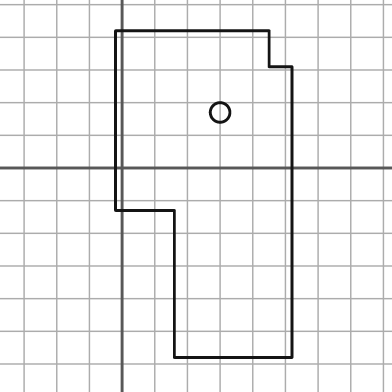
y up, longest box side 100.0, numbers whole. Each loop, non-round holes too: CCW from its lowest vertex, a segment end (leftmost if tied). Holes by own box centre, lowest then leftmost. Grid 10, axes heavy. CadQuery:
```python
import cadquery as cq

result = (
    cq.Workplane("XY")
    .moveTo(16.0, -58.0)
    .lineTo(52.0, -58.0)
    .lineTo(52.0, 31.0)
    .lineTo(45.0, 31.0)
    .lineTo(45.0, 42.0)
    .lineTo(-2.0, 42.0)
    .lineTo(-2.0, -13.0)
    .lineTo(16.0, -13.0)
    .close()
    .moveTo(30.0, 17.0)
    .circle(3.0)
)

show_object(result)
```